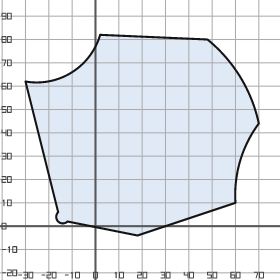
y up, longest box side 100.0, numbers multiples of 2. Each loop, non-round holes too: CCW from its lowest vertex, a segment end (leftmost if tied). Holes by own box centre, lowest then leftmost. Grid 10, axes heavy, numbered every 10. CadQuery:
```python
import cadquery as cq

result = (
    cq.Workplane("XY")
    .moveTo(18.0, -4.0)
    .lineTo(60.0, 10.0)
    .threePointArc((62.0, 28.0), (70.0, 44.0))
    .threePointArc((62.0, 64.0), (48.0, 80.0))
    .lineTo(2.0, 82.0)
    .threePointArc((-10.0, 66.0), (-30.0, 62.0))
    .lineTo(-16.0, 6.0)
    .threePointArc((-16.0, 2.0), (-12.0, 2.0))
    .close()
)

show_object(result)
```